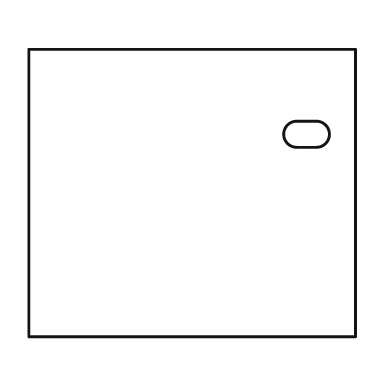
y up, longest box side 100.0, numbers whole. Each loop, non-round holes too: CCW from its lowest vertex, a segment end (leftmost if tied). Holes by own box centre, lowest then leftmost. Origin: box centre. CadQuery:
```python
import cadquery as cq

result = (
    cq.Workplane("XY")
    .moveTo(-50.0, -44.0)
    .lineTo(50.0, -44.0)
    .lineTo(50.0, 44.0)
    .lineTo(-50.0, 44.0)
    .close()
    .moveTo(32.0, 14.0)
    .lineTo(38.0, 14.0)
    .threePointArc((42.0, 18.0), (38.0, 22.0))
    .lineTo(32.0, 22.0)
    .threePointArc((28.0, 18.0), (32.0, 14.0))
    .close()
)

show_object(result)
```